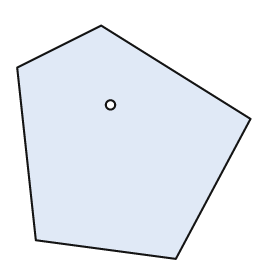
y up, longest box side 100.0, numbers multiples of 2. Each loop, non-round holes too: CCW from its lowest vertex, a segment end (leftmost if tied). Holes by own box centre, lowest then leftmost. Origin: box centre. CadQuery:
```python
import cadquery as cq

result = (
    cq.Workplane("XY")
    .moveTo(18.0, -50.0)
    .lineTo(50.0, 10.0)
    .lineTo(-14.0, 50.0)
    .lineTo(-50.0, 32.0)
    .lineTo(-42.0, -42.0)
    .close()
    .moveTo(-10.0, 16.0)
    .circle(2.0)
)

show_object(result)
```